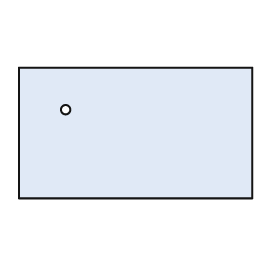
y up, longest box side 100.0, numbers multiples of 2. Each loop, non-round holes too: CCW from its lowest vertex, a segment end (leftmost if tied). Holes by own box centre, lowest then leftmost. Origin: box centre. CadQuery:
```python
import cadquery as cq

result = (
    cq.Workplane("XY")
    .moveTo(-50.0, -28.0)
    .lineTo(50.0, -28.0)
    .lineTo(50.0, 28.0)
    .lineTo(-50.0, 28.0)
    .close()
    .moveTo(-30.0, 10.0)
    .circle(2.0)
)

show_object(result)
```